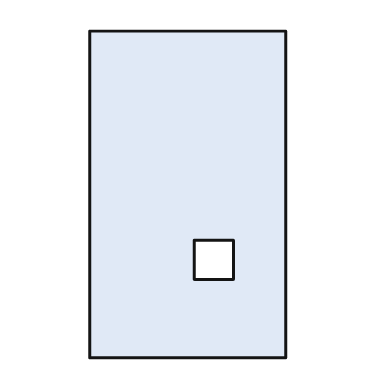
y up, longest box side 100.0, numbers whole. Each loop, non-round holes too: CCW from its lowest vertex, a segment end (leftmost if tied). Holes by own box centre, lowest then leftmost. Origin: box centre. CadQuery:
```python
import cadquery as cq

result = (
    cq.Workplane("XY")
    .moveTo(-30.0, -50.0)
    .lineTo(30.0, -50.0)
    .lineTo(30.0, 50.0)
    .lineTo(-30.0, 50.0)
    .close()
    .moveTo(2.0, -26.0)
    .lineTo(14.0, -26.0)
    .lineTo(14.0, -14.0)
    .lineTo(2.0, -14.0)
    .close()
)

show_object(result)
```